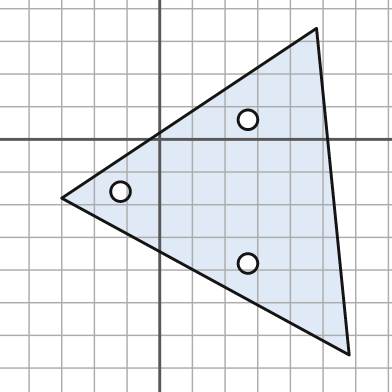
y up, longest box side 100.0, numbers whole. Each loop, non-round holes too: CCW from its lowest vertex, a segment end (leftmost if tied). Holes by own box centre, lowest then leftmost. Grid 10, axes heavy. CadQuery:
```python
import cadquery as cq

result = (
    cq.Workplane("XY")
    .moveTo(58.0, -66.0)
    .lineTo(48.0, 34.0)
    .lineTo(-30.0, -18.0)
    .close()
    .moveTo(27.0, -38.0)
    .circle(3.0)
    .moveTo(-12.0, -16.0)
    .circle(3.0)
    .moveTo(27.0, 6.0)
    .circle(3.0)
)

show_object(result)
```